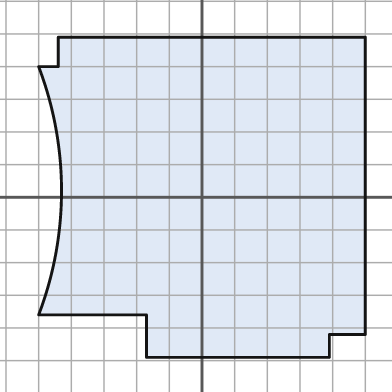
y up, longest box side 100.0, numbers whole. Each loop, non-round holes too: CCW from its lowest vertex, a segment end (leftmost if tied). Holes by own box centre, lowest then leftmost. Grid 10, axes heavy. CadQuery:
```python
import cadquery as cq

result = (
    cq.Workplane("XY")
    .moveTo(-17.0, -49.0)
    .lineTo(39.0, -49.0)
    .lineTo(39.0, -42.0)
    .lineTo(50.0, -42.0)
    .lineTo(50.0, 49.0)
    .lineTo(-44.0, 49.0)
    .lineTo(-44.0, 40.0)
    .lineTo(-50.0, 40.0)
    .threePointArc((-43.0, 2.0), (-50.0, -36.0))
    .lineTo(-17.0, -36.0)
    .close()
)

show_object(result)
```